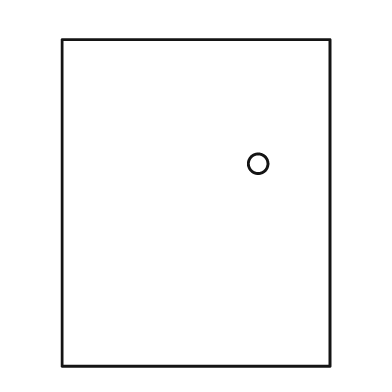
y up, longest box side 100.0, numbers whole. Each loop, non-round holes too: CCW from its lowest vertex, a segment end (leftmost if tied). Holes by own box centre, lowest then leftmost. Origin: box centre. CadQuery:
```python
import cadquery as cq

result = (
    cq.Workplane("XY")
    .moveTo(-41.0, -50.0)
    .lineTo(41.0, -50.0)
    .lineTo(41.0, 50.0)
    .lineTo(-41.0, 50.0)
    .close()
    .moveTo(19.0, 12.0)
    .circle(3.0)
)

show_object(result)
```